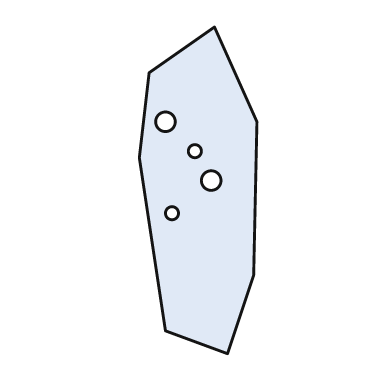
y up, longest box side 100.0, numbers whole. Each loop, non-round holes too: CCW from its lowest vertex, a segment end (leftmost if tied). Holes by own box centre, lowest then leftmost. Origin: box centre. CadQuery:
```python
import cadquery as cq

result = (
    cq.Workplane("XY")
    .moveTo(9.0, -50.0)
    .lineTo(17.0, -26.0)
    .lineTo(18.0, 21.0)
    .lineTo(5.0, 50.0)
    .lineTo(-15.0, 36.0)
    .lineTo(-18.0, 10.0)
    .lineTo(-10.0, -43.0)
    .close()
    .moveTo(-8.0, -7.0)
    .circle(2.0)
    .moveTo(4.0, 3.0)
    .circle(3.0)
    .moveTo(-1.0, 12.0)
    .circle(2.0)
    .moveTo(-10.0, 21.0)
    .circle(3.0)
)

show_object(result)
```